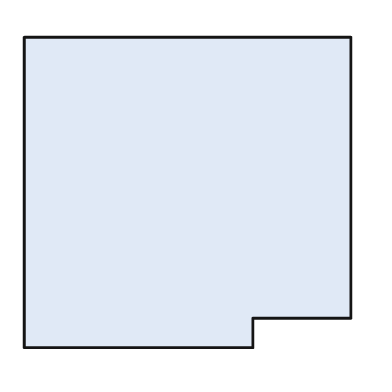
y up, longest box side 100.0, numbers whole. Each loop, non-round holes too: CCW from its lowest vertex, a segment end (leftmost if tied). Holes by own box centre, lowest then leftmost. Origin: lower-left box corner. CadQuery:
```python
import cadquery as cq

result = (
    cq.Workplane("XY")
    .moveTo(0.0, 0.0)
    .lineTo(70.0, 0.0)
    .lineTo(70.0, 9.0)
    .lineTo(100.0, 9.0)
    .lineTo(100.0, 95.0)
    .lineTo(0.0, 95.0)
    .close()
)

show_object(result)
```